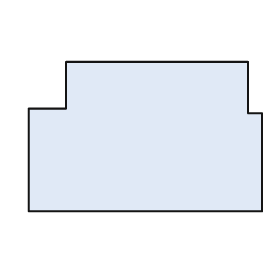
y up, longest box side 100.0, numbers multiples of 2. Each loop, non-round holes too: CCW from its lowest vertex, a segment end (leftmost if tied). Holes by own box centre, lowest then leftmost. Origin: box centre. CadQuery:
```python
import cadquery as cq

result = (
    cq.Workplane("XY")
    .moveTo(-50.0, -32.0)
    .lineTo(50.0, -32.0)
    .lineTo(50.0, 10.0)
    .lineTo(44.0, 10.0)
    .lineTo(44.0, 32.0)
    .lineTo(-34.0, 32.0)
    .lineTo(-34.0, 12.0)
    .lineTo(-50.0, 12.0)
    .close()
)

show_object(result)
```